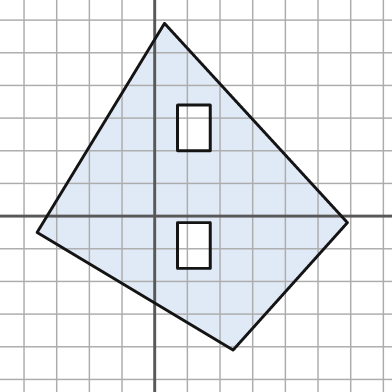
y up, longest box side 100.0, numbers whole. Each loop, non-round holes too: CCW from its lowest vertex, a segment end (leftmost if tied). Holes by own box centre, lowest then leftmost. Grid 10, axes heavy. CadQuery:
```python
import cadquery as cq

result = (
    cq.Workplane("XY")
    .moveTo(24.0, -41.0)
    .lineTo(59.0, -2.0)
    .lineTo(3.0, 59.0)
    .lineTo(-36.0, -5.0)
    .close()
    .moveTo(7.0, -16.0)
    .lineTo(17.0, -16.0)
    .lineTo(17.0, -2.0)
    .lineTo(7.0, -2.0)
    .close()
    .moveTo(7.0, 20.0)
    .lineTo(17.0, 20.0)
    .lineTo(17.0, 34.0)
    .lineTo(7.0, 34.0)
    .close()
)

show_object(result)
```